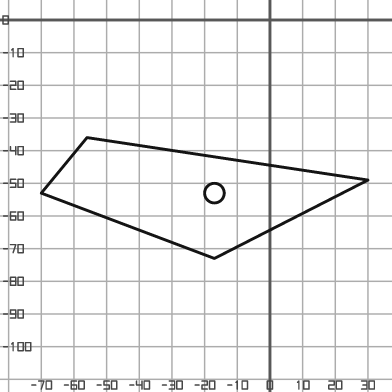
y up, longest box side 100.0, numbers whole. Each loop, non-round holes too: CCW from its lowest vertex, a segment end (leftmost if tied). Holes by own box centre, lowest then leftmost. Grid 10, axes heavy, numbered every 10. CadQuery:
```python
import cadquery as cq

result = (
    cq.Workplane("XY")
    .moveTo(-17.0, -73.0)
    .lineTo(30.0, -49.0)
    .lineTo(-56.0, -36.0)
    .lineTo(-70.0, -53.0)
    .close()
    .moveTo(-17.0, -53.0)
    .circle(3.0)
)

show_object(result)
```